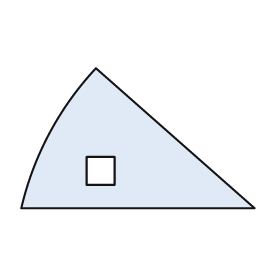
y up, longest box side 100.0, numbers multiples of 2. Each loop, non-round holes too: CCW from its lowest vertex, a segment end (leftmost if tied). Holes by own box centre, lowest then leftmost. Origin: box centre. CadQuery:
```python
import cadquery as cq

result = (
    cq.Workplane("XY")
    .moveTo(-50.0, -30.0)
    .lineTo(50.0, -30.0)
    .lineTo(-18.0, 30.0)
    .threePointArc((-38.0, 2.0), (-50.0, -30.0))
    .close()
    .moveTo(-22.0, -20.0)
    .lineTo(-10.0, -20.0)
    .lineTo(-10.0, -8.0)
    .lineTo(-22.0, -8.0)
    .close()
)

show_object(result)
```